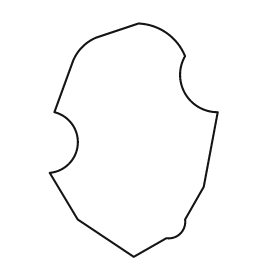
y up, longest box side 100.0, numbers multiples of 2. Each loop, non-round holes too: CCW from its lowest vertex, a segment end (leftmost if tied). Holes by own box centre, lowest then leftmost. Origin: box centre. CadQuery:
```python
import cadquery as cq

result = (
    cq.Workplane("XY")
    .moveTo(0.0, -50.0)
    .lineTo(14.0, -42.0)
    .threePointArc((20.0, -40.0), (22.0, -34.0))
    .lineTo(30.0, -20.0)
    .lineTo(36.0, 12.0)
    .threePointArc((22.0, 20.0), (22.0, 36.0))
    .threePointArc((14.0, 46.0), (2.0, 50.0))
    .lineTo(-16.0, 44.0)
    .threePointArc((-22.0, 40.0), (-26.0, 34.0))
    .lineTo(-34.0, 12.0)
    .threePointArc((-24.0, -2.0), (-36.0, -14.0))
    .lineTo(-24.0, -34.0)
    .close()
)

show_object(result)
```